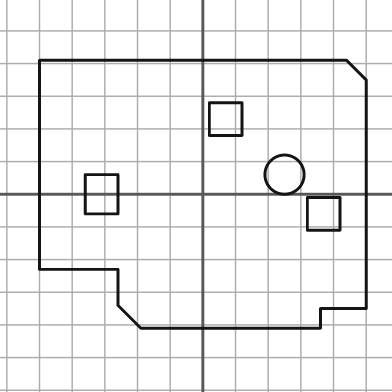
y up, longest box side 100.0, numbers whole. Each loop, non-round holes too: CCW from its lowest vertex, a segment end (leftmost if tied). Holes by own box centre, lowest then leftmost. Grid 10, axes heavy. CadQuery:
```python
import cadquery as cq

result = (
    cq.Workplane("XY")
    .moveTo(-19.0, -41.0)
    .lineTo(36.0, -41.0)
    .lineTo(36.0, -35.0)
    .lineTo(50.0, -35.0)
    .lineTo(50.0, 35.0)
    .lineTo(44.0, 41.0)
    .lineTo(-50.0, 41.0)
    .lineTo(-50.0, -23.0)
    .lineTo(-26.0, -23.0)
    .lineTo(-26.0, -34.0)
    .close()
    .moveTo(32.0, -11.0)
    .lineTo(42.0, -11.0)
    .lineTo(42.0, -1.0)
    .lineTo(32.0, -1.0)
    .close()
    .moveTo(-36.0, -6.0)
    .lineTo(-26.0, -6.0)
    .lineTo(-26.0, 6.0)
    .lineTo(-36.0, 6.0)
    .close()
    .moveTo(25.0, 6.0)
    .circle(6.0)
    .moveTo(2.0, 18.0)
    .lineTo(12.0, 18.0)
    .lineTo(12.0, 28.0)
    .lineTo(2.0, 28.0)
    .close()
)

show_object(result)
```